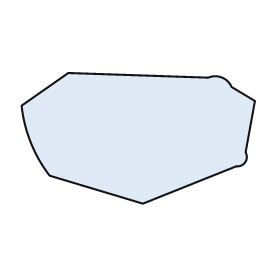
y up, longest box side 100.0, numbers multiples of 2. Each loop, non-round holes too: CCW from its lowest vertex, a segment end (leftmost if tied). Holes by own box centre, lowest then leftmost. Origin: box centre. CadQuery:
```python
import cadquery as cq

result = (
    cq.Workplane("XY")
    .moveTo(2.0, -28.0)
    .lineTo(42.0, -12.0)
    .threePointArc((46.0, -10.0), (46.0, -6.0))
    .lineTo(50.0, 16.0)
    .lineTo(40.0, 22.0)
    .threePointArc((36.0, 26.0), (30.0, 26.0))
    .lineTo(-30.0, 28.0)
    .lineTo(-50.0, 14.0)
    .threePointArc((-46.0, -2.0), (-38.0, -16.0))
    .close()
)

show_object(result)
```